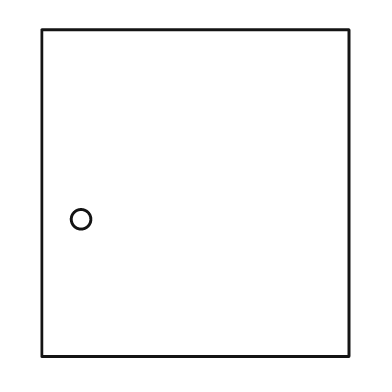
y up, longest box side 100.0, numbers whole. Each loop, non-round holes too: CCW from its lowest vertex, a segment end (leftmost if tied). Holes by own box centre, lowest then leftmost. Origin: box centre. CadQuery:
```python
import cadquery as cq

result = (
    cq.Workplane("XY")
    .moveTo(-47.0, -50.0)
    .lineTo(47.0, -50.0)
    .lineTo(47.0, 50.0)
    .lineTo(-47.0, 50.0)
    .close()
    .moveTo(-35.0, -8.0)
    .circle(3.0)
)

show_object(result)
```